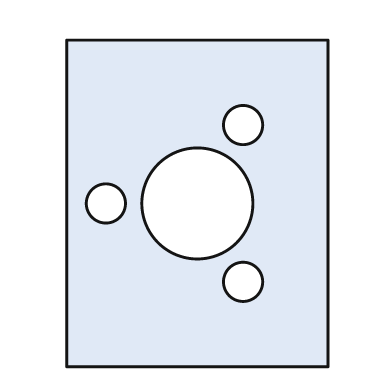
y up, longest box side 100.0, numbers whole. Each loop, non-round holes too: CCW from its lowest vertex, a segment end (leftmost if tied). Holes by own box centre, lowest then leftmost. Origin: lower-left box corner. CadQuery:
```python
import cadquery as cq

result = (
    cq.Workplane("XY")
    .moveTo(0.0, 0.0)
    .lineTo(80.0, 0.0)
    .lineTo(80.0, 100.0)
    .lineTo(0.0, 100.0)
    .close()
    .moveTo(54.0, 26.0)
    .circle(6.0)
    .moveTo(12.0, 50.0)
    .circle(6.0)
    .moveTo(40.0, 50.0)
    .circle(17.0)
    .moveTo(54.0, 74.0)
    .circle(6.0)
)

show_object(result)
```